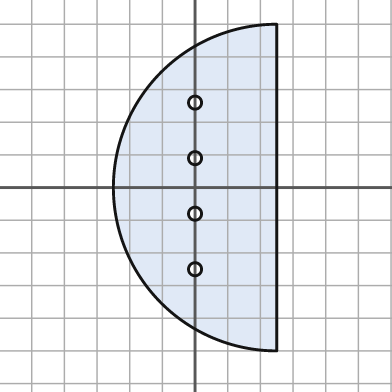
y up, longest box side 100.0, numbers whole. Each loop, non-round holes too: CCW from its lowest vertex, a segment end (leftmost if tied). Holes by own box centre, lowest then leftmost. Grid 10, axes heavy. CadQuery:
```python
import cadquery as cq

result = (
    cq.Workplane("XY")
    .moveTo(25.0, -50.0)
    .lineTo(25.0, 50.0)
    .threePointArc((-25.0, 0.0), (25.0, -50.0))
    .close()
    .moveTo(0.0, -25.0)
    .circle(2.0)
    .moveTo(0.0, -8.0)
    .circle(2.0)
    .moveTo(0.0, 9.0)
    .circle(2.0)
    .moveTo(0.0, 26.0)
    .circle(2.0)
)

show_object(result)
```